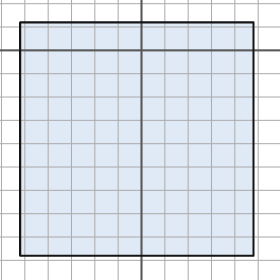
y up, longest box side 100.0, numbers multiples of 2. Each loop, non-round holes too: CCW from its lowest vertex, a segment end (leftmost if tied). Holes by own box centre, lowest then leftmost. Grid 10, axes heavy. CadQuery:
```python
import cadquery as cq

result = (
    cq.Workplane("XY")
    .moveTo(-52.0, -88.0)
    .lineTo(48.0, -88.0)
    .lineTo(48.0, 12.0)
    .lineTo(-52.0, 12.0)
    .close()
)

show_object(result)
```